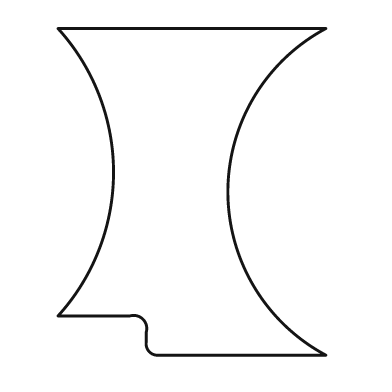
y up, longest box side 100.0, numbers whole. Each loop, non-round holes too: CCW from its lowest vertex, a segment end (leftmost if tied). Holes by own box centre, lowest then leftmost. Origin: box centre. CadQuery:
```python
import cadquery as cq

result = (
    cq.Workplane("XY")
    .moveTo(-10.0, -50.0)
    .lineTo(41.0, -50.0)
    .threePointArc((11.0, 0.0), (41.0, 50.0))
    .lineTo(-41.0, 50.0)
    .threePointArc((-24.0, 6.0), (-41.0, -38.0))
    .lineTo(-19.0, -38.0)
    .threePointArc((-15.0, -39.0), (-14.0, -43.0))
    .lineTo(-14.0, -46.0)
    .threePointArc((-13.0, -49.0), (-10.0, -50.0))
    .close()
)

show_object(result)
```